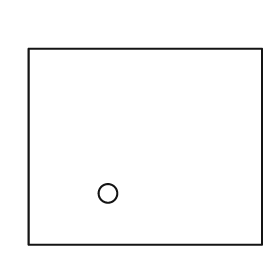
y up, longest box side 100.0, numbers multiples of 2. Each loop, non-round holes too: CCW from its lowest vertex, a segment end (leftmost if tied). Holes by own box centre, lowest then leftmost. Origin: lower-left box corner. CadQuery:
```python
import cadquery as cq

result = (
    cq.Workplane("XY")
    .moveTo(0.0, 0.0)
    .lineTo(100.0, 0.0)
    .lineTo(100.0, 84.0)
    .lineTo(0.0, 84.0)
    .close()
    .moveTo(34.0, 22.0)
    .circle(4.0)
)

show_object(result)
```